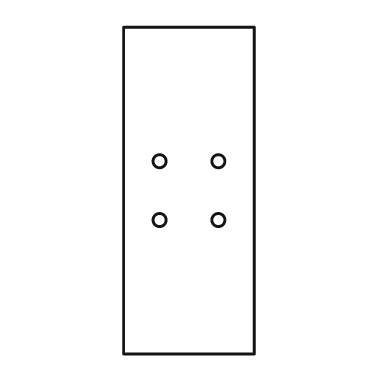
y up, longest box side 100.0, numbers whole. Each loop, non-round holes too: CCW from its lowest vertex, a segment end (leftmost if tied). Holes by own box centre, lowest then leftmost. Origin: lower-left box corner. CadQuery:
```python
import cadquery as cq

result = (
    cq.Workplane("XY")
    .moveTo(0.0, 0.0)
    .lineTo(40.0, 0.0)
    .lineTo(40.0, 100.0)
    .lineTo(0.0, 100.0)
    .close()
    .moveTo(11.0, 41.0)
    .circle(2.0)
    .moveTo(29.0, 41.0)
    .circle(2.0)
    .moveTo(11.0, 59.0)
    .circle(2.0)
    .moveTo(29.0, 59.0)
    .circle(2.0)
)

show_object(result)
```